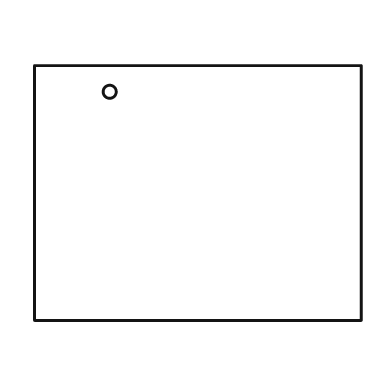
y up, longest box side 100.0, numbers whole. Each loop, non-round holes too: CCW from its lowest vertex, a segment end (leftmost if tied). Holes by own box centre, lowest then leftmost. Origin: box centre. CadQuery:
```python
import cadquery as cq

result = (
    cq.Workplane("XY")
    .moveTo(-50.0, -39.0)
    .lineTo(50.0, -39.0)
    .lineTo(50.0, 39.0)
    .lineTo(-50.0, 39.0)
    .close()
    .moveTo(-27.0, 31.0)
    .circle(2.0)
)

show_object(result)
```